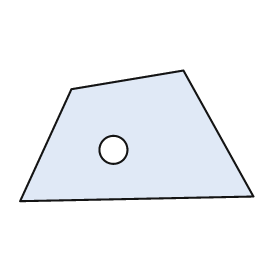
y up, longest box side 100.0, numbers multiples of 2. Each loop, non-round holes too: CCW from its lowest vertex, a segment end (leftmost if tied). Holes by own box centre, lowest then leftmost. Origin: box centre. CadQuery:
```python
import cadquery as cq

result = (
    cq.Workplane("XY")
    .moveTo(-50.0, -28.0)
    .lineTo(50.0, -26.0)
    .lineTo(20.0, 28.0)
    .lineTo(-28.0, 20.0)
    .close()
    .moveTo(-10.0, -6.0)
    .circle(6.0)
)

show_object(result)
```